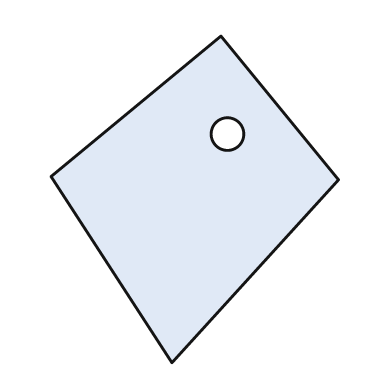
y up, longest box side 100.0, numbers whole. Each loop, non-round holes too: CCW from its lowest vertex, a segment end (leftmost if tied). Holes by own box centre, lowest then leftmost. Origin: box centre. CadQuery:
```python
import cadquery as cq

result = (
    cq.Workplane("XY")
    .moveTo(-7.0, -50.0)
    .lineTo(44.0, 6.0)
    .lineTo(8.0, 50.0)
    .lineTo(-44.0, 7.0)
    .close()
    .moveTo(10.0, 20.0)
    .circle(5.0)
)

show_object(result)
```